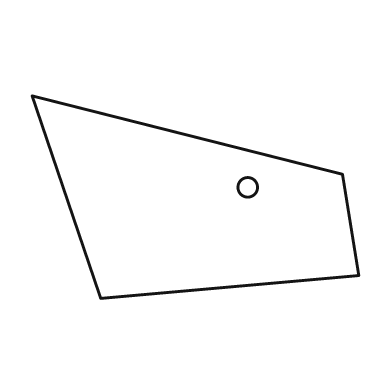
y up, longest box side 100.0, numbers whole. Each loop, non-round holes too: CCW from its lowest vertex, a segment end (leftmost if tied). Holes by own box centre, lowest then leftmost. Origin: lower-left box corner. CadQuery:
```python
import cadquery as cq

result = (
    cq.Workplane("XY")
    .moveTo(21.0, 0.0)
    .lineTo(100.0, 7.0)
    .lineTo(95.0, 38.0)
    .lineTo(0.0, 62.0)
    .close()
    .moveTo(66.0, 34.0)
    .circle(3.0)
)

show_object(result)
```